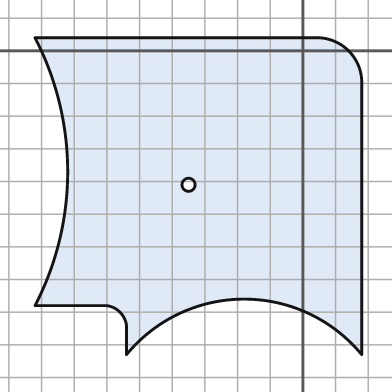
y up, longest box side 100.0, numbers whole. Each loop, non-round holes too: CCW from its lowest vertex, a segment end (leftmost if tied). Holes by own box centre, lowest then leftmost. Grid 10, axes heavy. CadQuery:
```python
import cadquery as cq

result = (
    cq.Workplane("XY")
    .moveTo(-54.0, -93.0)
    .threePointArc((-18.0, -76.0), (18.0, -93.0))
    .lineTo(18.0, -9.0)
    .threePointArc((14.0, 0.0), (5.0, 4.0))
    .lineTo(-82.0, 4.0)
    .threePointArc((-72.0, -37.0), (-82.0, -78.0))
    .lineTo(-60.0, -78.0)
    .threePointArc((-56.0, -80.0), (-54.0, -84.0))
    .close()
    .moveTo(-35.0, -41.0)
    .circle(2.0)
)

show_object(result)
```